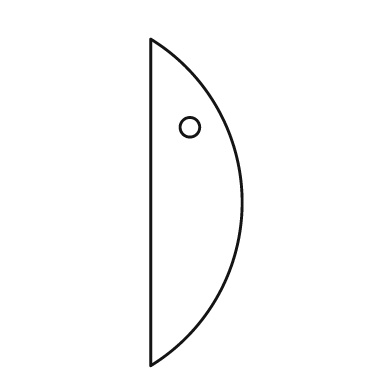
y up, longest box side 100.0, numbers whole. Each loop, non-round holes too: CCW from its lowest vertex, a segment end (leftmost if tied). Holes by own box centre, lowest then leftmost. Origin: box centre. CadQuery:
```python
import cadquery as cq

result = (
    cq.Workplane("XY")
    .moveTo(-14.0, -50.0)
    .threePointArc((14.0, 0.0), (-14.0, 50.0))
    .close()
    .moveTo(-2.0, 23.0)
    .circle(3.0)
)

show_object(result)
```